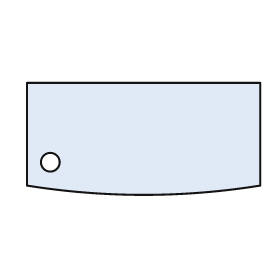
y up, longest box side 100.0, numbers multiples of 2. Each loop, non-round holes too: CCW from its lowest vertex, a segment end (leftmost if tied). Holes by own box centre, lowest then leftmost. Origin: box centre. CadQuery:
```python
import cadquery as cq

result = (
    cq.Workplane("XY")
    .moveTo(-50.0, -20.0)
    .threePointArc((0.0, -24.0), (50.0, -20.0))
    .lineTo(50.0, 24.0)
    .lineTo(-50.0, 24.0)
    .close()
    .moveTo(-40.0, -10.0)
    .circle(4.0)
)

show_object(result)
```